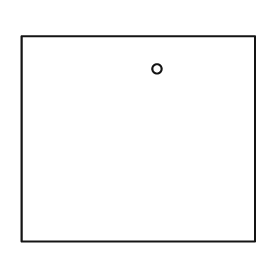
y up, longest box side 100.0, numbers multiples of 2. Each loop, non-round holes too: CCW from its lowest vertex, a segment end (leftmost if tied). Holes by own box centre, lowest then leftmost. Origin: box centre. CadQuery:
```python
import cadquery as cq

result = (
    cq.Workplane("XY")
    .moveTo(-50.0, -44.0)
    .lineTo(50.0, -44.0)
    .lineTo(50.0, 44.0)
    .lineTo(-50.0, 44.0)
    .close()
    .moveTo(8.0, 30.0)
    .circle(2.0)
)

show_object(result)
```